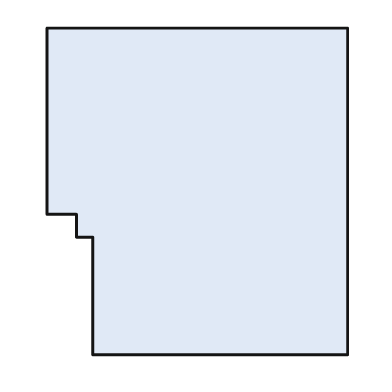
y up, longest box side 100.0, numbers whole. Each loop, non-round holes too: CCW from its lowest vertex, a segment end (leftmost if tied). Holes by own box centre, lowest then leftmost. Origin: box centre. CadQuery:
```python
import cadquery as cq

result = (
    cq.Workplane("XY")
    .moveTo(-32.0, -50.0)
    .lineTo(46.0, -50.0)
    .lineTo(46.0, 50.0)
    .lineTo(-46.0, 50.0)
    .lineTo(-46.0, -7.0)
    .lineTo(-37.0, -7.0)
    .lineTo(-37.0, -14.0)
    .lineTo(-32.0, -14.0)
    .close()
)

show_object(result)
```